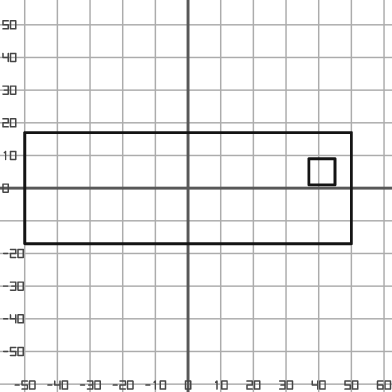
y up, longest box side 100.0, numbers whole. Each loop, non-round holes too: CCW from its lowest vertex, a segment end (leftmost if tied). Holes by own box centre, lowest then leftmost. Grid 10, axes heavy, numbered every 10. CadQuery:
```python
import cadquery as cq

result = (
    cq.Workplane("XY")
    .moveTo(-50.0, -17.0)
    .lineTo(50.0, -17.0)
    .lineTo(50.0, 17.0)
    .lineTo(-50.0, 17.0)
    .close()
    .moveTo(37.0, 1.0)
    .lineTo(45.0, 1.0)
    .lineTo(45.0, 9.0)
    .lineTo(37.0, 9.0)
    .close()
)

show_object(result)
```